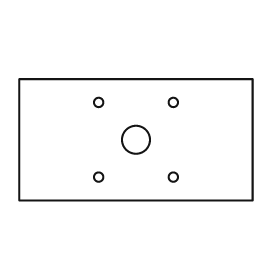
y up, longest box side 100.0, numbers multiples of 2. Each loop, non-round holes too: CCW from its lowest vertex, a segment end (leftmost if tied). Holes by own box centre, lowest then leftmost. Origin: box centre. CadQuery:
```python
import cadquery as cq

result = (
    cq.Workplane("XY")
    .moveTo(-50.0, -26.0)
    .lineTo(50.0, -26.0)
    .lineTo(50.0, 26.0)
    .lineTo(-50.0, 26.0)
    .close()
    .moveTo(-16.0, -16.0)
    .circle(2.0)
    .moveTo(16.0, -16.0)
    .circle(2.0)
    .moveTo(0.0, 0.0)
    .circle(6.0)
    .moveTo(-16.0, 16.0)
    .circle(2.0)
    .moveTo(16.0, 16.0)
    .circle(2.0)
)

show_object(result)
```